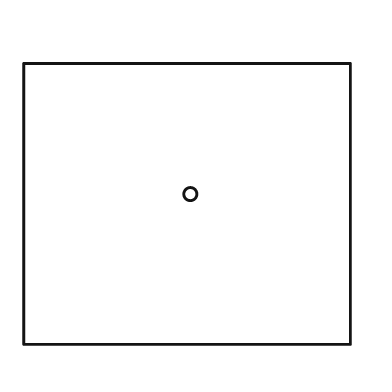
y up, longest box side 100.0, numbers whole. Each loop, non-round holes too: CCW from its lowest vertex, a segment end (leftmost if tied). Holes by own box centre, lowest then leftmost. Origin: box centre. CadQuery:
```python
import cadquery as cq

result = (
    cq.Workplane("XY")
    .moveTo(-50.0, -43.0)
    .lineTo(50.0, -43.0)
    .lineTo(50.0, 43.0)
    .lineTo(-50.0, 43.0)
    .close()
    .moveTo(1.0, 3.0)
    .circle(2.0)
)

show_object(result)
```